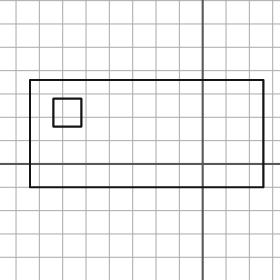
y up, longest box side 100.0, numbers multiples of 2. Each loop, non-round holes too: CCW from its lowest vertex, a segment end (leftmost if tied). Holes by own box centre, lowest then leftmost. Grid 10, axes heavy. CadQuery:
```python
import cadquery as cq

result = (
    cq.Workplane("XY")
    .moveTo(-74.0, -10.0)
    .lineTo(26.0, -10.0)
    .lineTo(26.0, 36.0)
    .lineTo(-74.0, 36.0)
    .close()
    .moveTo(-64.0, 16.0)
    .lineTo(-52.0, 16.0)
    .lineTo(-52.0, 28.0)
    .lineTo(-64.0, 28.0)
    .close()
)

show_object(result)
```